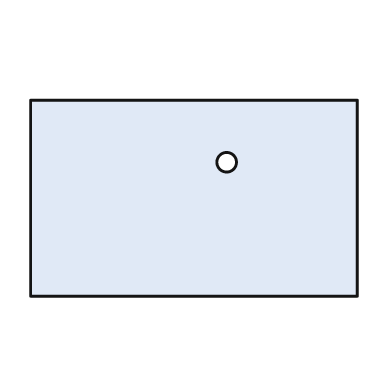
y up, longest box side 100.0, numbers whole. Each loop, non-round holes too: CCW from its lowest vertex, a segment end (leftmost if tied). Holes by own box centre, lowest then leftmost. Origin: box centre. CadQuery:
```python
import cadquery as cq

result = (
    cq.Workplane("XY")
    .moveTo(-50.0, -30.0)
    .lineTo(50.0, -30.0)
    .lineTo(50.0, 30.0)
    .lineTo(-50.0, 30.0)
    .close()
    .moveTo(10.0, 11.0)
    .circle(3.0)
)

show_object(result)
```